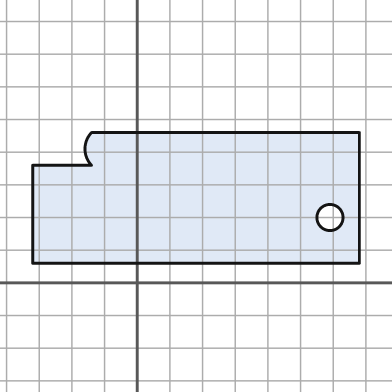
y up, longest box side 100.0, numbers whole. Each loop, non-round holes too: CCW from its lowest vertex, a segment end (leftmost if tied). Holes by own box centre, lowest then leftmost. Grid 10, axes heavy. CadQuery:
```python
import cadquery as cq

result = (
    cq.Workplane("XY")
    .moveTo(-32.0, 6.0)
    .lineTo(68.0, 6.0)
    .lineTo(68.0, 46.0)
    .lineTo(-14.0, 46.0)
    .threePointArc((-16.0, 41.0), (-14.0, 36.0))
    .lineTo(-32.0, 36.0)
    .close()
    .moveTo(59.0, 20.0)
    .circle(4.0)
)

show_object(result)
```